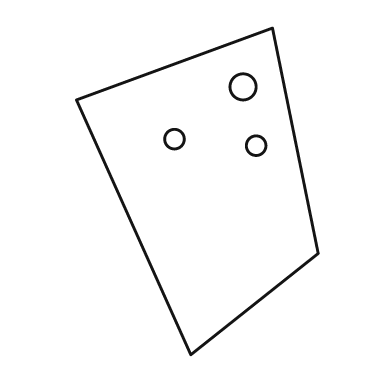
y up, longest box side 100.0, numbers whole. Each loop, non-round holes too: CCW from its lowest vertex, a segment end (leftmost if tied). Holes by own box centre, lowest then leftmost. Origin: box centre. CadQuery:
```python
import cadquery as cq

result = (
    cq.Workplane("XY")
    .moveTo(-2.0, -50.0)
    .lineTo(37.0, -19.0)
    .lineTo(23.0, 50.0)
    .lineTo(-37.0, 28.0)
    .close()
    .moveTo(18.0, 14.0)
    .circle(3.0)
    .moveTo(-7.0, 16.0)
    .circle(3.0)
    .moveTo(14.0, 32.0)
    .circle(4.0)
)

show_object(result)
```